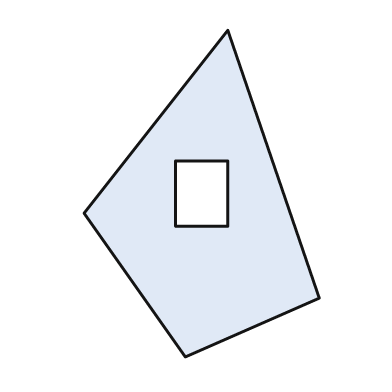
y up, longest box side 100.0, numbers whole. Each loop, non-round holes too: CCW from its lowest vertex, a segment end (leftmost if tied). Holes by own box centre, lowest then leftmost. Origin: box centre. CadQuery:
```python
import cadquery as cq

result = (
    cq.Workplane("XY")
    .moveTo(-5.0, -50.0)
    .lineTo(36.0, -32.0)
    .lineTo(8.0, 50.0)
    .lineTo(-36.0, -6.0)
    .close()
    .moveTo(-8.0, -10.0)
    .lineTo(8.0, -10.0)
    .lineTo(8.0, 10.0)
    .lineTo(-8.0, 10.0)
    .close()
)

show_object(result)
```